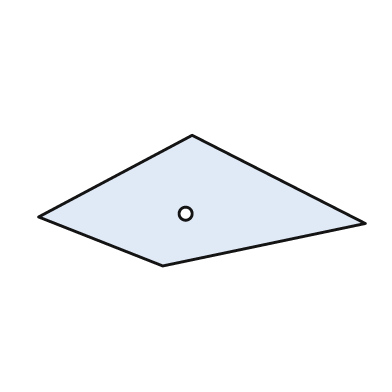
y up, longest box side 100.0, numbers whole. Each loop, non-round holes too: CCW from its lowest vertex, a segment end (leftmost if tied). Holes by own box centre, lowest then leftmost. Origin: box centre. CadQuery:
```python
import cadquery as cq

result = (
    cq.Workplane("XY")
    .moveTo(-12.0, -20.0)
    .lineTo(50.0, -7.0)
    .lineTo(-3.0, 20.0)
    .lineTo(-50.0, -5.0)
    .close()
    .moveTo(-5.0, -4.0)
    .circle(2.0)
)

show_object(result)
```